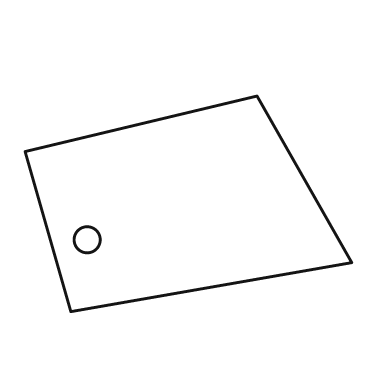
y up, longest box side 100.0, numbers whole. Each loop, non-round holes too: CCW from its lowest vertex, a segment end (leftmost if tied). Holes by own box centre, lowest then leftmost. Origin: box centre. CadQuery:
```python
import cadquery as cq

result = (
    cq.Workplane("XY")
    .moveTo(-36.0, -33.0)
    .lineTo(50.0, -18.0)
    .lineTo(21.0, 33.0)
    .lineTo(-50.0, 16.0)
    .close()
    .moveTo(-31.0, -11.0)
    .circle(4.0)
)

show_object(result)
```